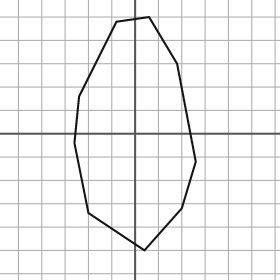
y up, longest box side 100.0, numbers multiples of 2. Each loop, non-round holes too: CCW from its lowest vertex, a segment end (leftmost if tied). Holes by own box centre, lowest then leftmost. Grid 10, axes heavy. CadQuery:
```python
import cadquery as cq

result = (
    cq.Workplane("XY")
    .moveTo(4.0, -50.0)
    .lineTo(20.0, -32.0)
    .lineTo(26.0, -12.0)
    .lineTo(18.0, 30.0)
    .lineTo(6.0, 50.0)
    .lineTo(-8.0, 48.0)
    .lineTo(-24.0, 16.0)
    .lineTo(-26.0, -4.0)
    .lineTo(-20.0, -34.0)
    .close()
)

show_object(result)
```